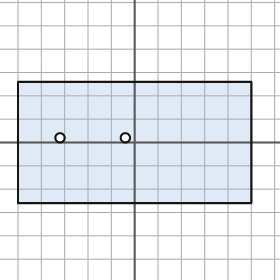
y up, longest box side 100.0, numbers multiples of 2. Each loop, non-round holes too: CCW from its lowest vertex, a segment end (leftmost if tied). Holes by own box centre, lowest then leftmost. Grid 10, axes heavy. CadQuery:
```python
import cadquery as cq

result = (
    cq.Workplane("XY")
    .moveTo(-50.0, -26.0)
    .lineTo(50.0, -26.0)
    .lineTo(50.0, 26.0)
    .lineTo(-50.0, 26.0)
    .close()
    .moveTo(-32.0, 2.0)
    .circle(2.0)
    .moveTo(-4.0, 2.0)
    .circle(2.0)
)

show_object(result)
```